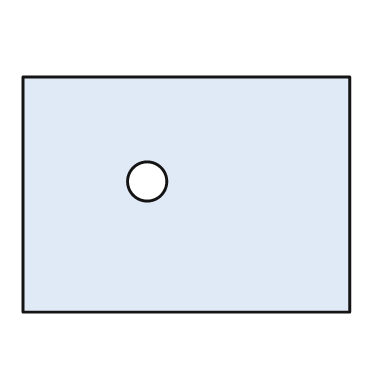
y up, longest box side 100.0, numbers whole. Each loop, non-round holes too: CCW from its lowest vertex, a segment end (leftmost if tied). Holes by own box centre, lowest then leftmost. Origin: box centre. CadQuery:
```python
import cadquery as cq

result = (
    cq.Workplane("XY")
    .moveTo(-50.0, -36.0)
    .lineTo(50.0, -36.0)
    .lineTo(50.0, 36.0)
    .lineTo(-50.0, 36.0)
    .close()
    .moveTo(-12.0, 4.0)
    .circle(6.0)
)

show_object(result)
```